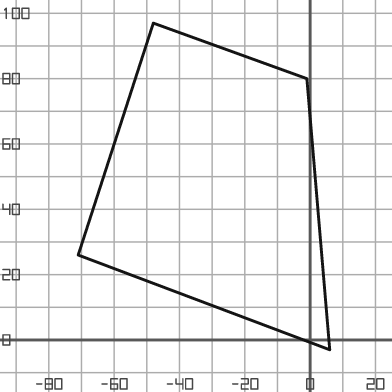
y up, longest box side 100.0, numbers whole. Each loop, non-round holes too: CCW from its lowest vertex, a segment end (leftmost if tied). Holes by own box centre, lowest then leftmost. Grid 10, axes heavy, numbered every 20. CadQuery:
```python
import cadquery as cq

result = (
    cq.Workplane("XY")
    .moveTo(6.0, -3.0)
    .lineTo(-1.0, 80.0)
    .lineTo(-48.0, 97.0)
    .lineTo(-71.0, 26.0)
    .close()
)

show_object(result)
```